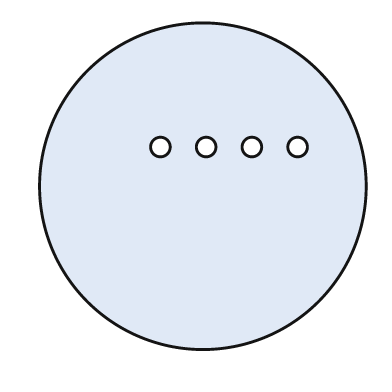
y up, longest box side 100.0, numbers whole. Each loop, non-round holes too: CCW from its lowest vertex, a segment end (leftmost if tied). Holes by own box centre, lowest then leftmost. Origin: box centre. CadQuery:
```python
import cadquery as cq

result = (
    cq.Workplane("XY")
    .moveTo(0.0, 0.0)
    .circle(50.0)
    .moveTo(-13.0, 12.0)
    .circle(3.0)
    .moveTo(1.0, 12.0)
    .circle(3.0)
    .moveTo(15.0, 12.0)
    .circle(3.0)
    .moveTo(29.0, 12.0)
    .circle(3.0)
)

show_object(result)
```